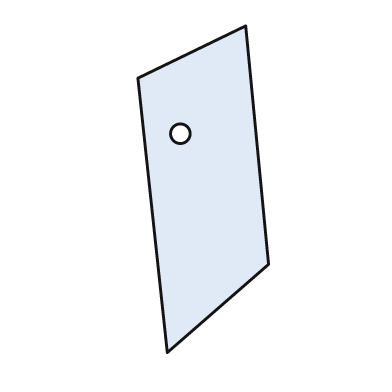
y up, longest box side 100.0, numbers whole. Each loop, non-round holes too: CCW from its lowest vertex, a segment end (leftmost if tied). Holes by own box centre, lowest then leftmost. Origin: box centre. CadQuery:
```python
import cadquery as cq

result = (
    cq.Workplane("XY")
    .moveTo(-11.0, -50.0)
    .lineTo(20.0, -23.0)
    .lineTo(13.0, 50.0)
    .lineTo(-20.0, 34.0)
    .close()
    .moveTo(-7.0, 17.0)
    .circle(3.0)
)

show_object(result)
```